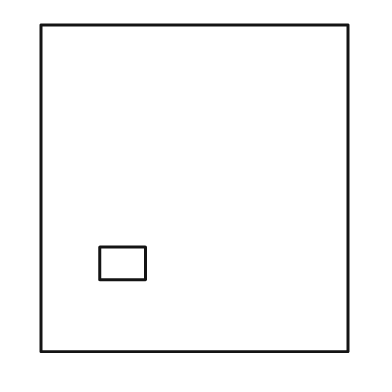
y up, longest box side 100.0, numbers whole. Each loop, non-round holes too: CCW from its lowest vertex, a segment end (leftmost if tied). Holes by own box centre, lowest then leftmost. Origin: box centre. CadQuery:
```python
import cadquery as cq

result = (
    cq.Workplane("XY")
    .moveTo(-47.0, -50.0)
    .lineTo(47.0, -50.0)
    .lineTo(47.0, 50.0)
    .lineTo(-47.0, 50.0)
    .close()
    .moveTo(-29.0, -28.0)
    .lineTo(-15.0, -28.0)
    .lineTo(-15.0, -18.0)
    .lineTo(-29.0, -18.0)
    .close()
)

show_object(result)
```